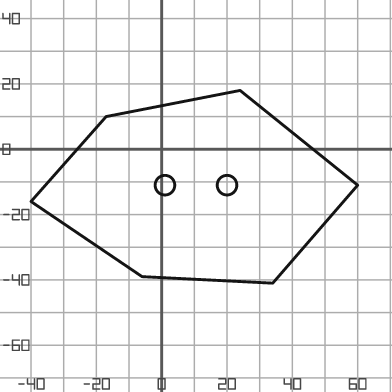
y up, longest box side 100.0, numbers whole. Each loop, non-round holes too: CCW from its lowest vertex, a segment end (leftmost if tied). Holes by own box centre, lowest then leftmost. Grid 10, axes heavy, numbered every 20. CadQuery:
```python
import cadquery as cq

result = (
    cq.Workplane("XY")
    .moveTo(34.0, -41.0)
    .lineTo(60.0, -11.0)
    .lineTo(24.0, 18.0)
    .lineTo(-17.0, 10.0)
    .lineTo(-40.0, -16.0)
    .lineTo(-6.0, -39.0)
    .close()
    .moveTo(1.0, -11.0)
    .circle(3.0)
    .moveTo(20.0, -11.0)
    .circle(3.0)
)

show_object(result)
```